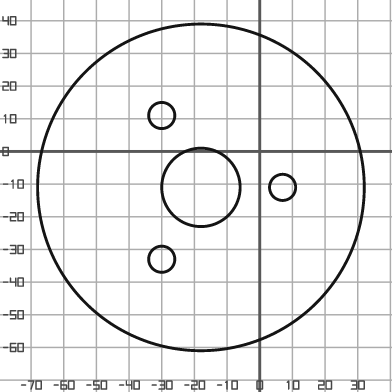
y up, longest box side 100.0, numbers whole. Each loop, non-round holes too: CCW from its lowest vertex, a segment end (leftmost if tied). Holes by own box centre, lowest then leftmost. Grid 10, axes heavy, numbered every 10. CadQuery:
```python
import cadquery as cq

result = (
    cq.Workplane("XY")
    .moveTo(-18.0, -11.0)
    .circle(50.0)
    .moveTo(-30.0, -33.0)
    .circle(4.0)
    .moveTo(-18.0, -11.0)
    .circle(12.0)
    .moveTo(7.0, -11.0)
    .circle(4.0)
    .moveTo(-30.0, 11.0)
    .circle(4.0)
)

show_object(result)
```